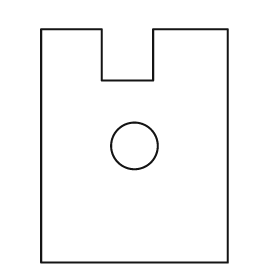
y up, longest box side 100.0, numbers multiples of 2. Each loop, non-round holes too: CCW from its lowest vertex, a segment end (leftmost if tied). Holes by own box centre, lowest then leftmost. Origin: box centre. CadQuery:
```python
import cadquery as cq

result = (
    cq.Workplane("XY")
    .moveTo(-40.0, -50.0)
    .lineTo(40.0, -50.0)
    .lineTo(40.0, 50.0)
    .lineTo(8.0, 50.0)
    .lineTo(8.0, 28.0)
    .lineTo(-14.0, 28.0)
    .lineTo(-14.0, 50.0)
    .lineTo(-40.0, 50.0)
    .close()
    .moveTo(0.0, 0.0)
    .circle(10.0)
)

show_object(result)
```